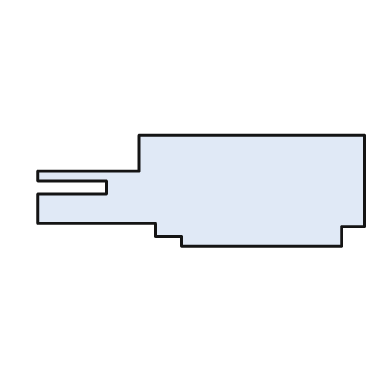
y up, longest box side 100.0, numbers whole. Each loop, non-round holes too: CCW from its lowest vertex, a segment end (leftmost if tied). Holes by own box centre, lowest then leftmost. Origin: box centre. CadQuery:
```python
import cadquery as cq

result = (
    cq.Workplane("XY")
    .moveTo(-6.0, -17.0)
    .lineTo(43.0, -17.0)
    .lineTo(43.0, -11.0)
    .lineTo(50.0, -11.0)
    .lineTo(50.0, 17.0)
    .lineTo(-19.0, 17.0)
    .lineTo(-19.0, 6.0)
    .lineTo(-50.0, 6.0)
    .lineTo(-50.0, 3.0)
    .lineTo(-29.0, 3.0)
    .lineTo(-29.0, -1.0)
    .lineTo(-50.0, -1.0)
    .lineTo(-50.0, -10.0)
    .lineTo(-14.0, -10.0)
    .lineTo(-14.0, -14.0)
    .lineTo(-6.0, -14.0)
    .close()
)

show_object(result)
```